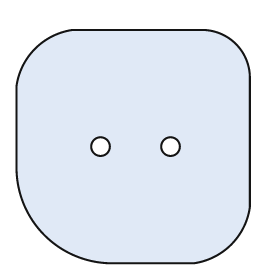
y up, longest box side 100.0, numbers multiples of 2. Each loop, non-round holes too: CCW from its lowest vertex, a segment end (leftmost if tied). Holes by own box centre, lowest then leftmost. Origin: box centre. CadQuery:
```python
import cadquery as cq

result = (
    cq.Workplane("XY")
    .moveTo(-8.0, -50.0)
    .lineTo(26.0, -50.0)
    .threePointArc((42.0, -42.0), (50.0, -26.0))
    .lineTo(50.0, 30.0)
    .threePointArc((44.0, 44.0), (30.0, 50.0))
    .lineTo(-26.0, 50.0)
    .threePointArc((-42.0, 42.0), (-50.0, 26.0))
    .lineTo(-50.0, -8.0)
    .threePointArc((-38.0, -38.0), (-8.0, -50.0))
    .close()
    .moveTo(-14.0, 0.0)
    .circle(4.0)
    .moveTo(16.0, 0.0)
    .circle(4.0)
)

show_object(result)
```